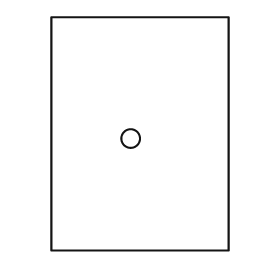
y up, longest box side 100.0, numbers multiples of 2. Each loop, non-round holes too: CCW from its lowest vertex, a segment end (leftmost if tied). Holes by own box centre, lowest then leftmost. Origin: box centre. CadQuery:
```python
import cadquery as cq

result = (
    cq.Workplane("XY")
    .moveTo(-38.0, -50.0)
    .lineTo(38.0, -50.0)
    .lineTo(38.0, 50.0)
    .lineTo(-38.0, 50.0)
    .close()
    .moveTo(-4.0, -2.0)
    .circle(4.0)
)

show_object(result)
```